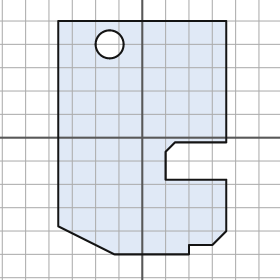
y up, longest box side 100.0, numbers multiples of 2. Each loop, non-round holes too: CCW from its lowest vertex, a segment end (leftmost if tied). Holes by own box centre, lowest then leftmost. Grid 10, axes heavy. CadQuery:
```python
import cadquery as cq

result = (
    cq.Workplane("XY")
    .moveTo(-12.0, -50.0)
    .lineTo(20.0, -50.0)
    .lineTo(20.0, -46.0)
    .lineTo(30.0, -46.0)
    .lineTo(36.0, -40.0)
    .lineTo(36.0, -18.0)
    .lineTo(10.0, -18.0)
    .lineTo(10.0, -6.0)
    .lineTo(14.0, -2.0)
    .lineTo(36.0, -2.0)
    .lineTo(36.0, 50.0)
    .lineTo(-36.0, 50.0)
    .lineTo(-36.0, -38.0)
    .close()
    .moveTo(-14.0, 40.0)
    .circle(6.0)
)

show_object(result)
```